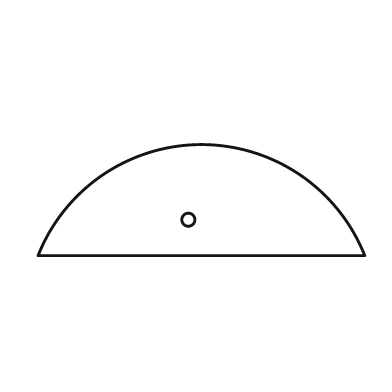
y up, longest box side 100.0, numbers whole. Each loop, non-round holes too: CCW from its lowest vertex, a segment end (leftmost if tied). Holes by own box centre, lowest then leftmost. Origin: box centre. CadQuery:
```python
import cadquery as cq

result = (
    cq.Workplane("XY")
    .moveTo(-50.0, -17.0)
    .lineTo(50.0, -17.0)
    .threePointArc((0.0, 17.0), (-50.0, -17.0))
    .close()
    .moveTo(-4.0, -6.0)
    .circle(2.0)
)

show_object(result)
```